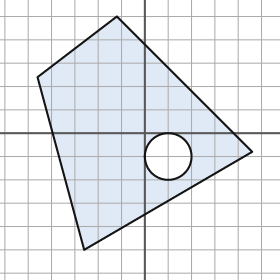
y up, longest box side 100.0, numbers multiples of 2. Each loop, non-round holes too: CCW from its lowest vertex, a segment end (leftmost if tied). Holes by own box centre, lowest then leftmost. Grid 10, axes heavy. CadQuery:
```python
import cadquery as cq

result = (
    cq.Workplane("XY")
    .moveTo(-26.0, -50.0)
    .lineTo(46.0, -8.0)
    .lineTo(-12.0, 50.0)
    .lineTo(-46.0, 24.0)
    .close()
    .moveTo(10.0, -10.0)
    .circle(10.0)
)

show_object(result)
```